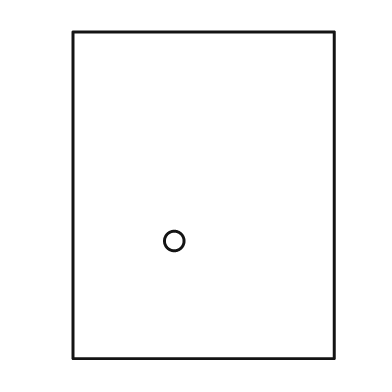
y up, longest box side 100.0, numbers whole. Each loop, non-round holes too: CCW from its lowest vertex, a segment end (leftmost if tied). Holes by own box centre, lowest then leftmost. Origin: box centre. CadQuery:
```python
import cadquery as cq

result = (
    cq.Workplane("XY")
    .moveTo(-40.0, -50.0)
    .lineTo(40.0, -50.0)
    .lineTo(40.0, 50.0)
    .lineTo(-40.0, 50.0)
    .close()
    .moveTo(-9.0, -14.0)
    .circle(3.0)
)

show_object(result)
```